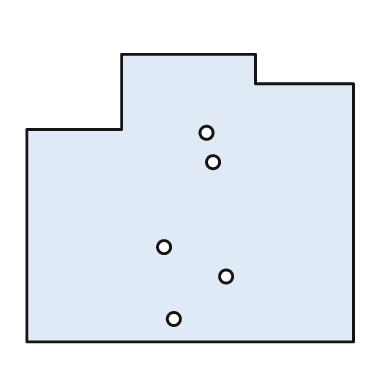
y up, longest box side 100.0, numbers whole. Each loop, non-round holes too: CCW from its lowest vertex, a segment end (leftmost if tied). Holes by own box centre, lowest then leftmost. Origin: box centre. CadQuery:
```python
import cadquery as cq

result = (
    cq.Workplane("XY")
    .moveTo(-50.0, -44.0)
    .lineTo(50.0, -44.0)
    .lineTo(50.0, 35.0)
    .lineTo(20.0, 35.0)
    .lineTo(20.0, 44.0)
    .lineTo(-21.0, 44.0)
    .lineTo(-21.0, 21.0)
    .lineTo(-50.0, 21.0)
    .close()
    .moveTo(-5.0, -37.0)
    .circle(2.0)
    .moveTo(11.0, -24.0)
    .circle(2.0)
    .moveTo(-8.0, -15.0)
    .circle(2.0)
    .moveTo(7.0, 11.0)
    .circle(2.0)
    .moveTo(5.0, 20.0)
    .circle(2.0)
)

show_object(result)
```